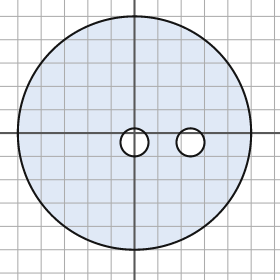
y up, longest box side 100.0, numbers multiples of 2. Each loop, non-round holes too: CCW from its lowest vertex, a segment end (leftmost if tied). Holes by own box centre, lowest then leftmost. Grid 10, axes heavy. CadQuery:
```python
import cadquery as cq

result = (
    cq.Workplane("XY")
    .moveTo(0.0, 0.0)
    .circle(50.0)
    .moveTo(0.0, -4.0)
    .circle(6.0)
    .moveTo(24.0, -4.0)
    .circle(6.0)
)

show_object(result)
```